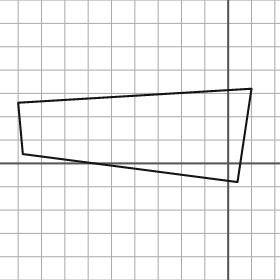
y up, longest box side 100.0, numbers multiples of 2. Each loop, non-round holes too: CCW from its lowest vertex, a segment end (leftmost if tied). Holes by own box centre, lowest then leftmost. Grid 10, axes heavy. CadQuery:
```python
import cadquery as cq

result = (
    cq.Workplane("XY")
    .moveTo(4.0, -8.0)
    .lineTo(10.0, 32.0)
    .lineTo(-90.0, 26.0)
    .lineTo(-88.0, 4.0)
    .close()
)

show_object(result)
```